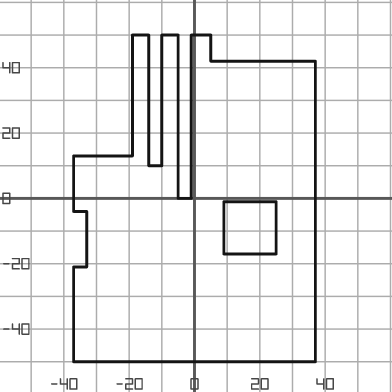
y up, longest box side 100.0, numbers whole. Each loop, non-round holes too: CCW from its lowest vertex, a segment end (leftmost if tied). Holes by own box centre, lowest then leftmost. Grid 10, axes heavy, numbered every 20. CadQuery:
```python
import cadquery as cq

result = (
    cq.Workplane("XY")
    .moveTo(-37.0, -50.0)
    .lineTo(37.0, -50.0)
    .lineTo(37.0, 42.0)
    .lineTo(5.0, 42.0)
    .lineTo(5.0, 50.0)
    .lineTo(-1.0, 50.0)
    .lineTo(-1.0, 0.0)
    .lineTo(-5.0, 0.0)
    .lineTo(-5.0, 50.0)
    .lineTo(-10.0, 50.0)
    .lineTo(-10.0, 10.0)
    .lineTo(-14.0, 10.0)
    .lineTo(-14.0, 50.0)
    .lineTo(-19.0, 50.0)
    .lineTo(-19.0, 13.0)
    .lineTo(-37.0, 13.0)
    .lineTo(-37.0, -4.0)
    .lineTo(-33.0, -4.0)
    .lineTo(-33.0, -21.0)
    .lineTo(-37.0, -21.0)
    .close()
    .moveTo(9.0, -17.0)
    .lineTo(25.0, -17.0)
    .lineTo(25.0, -1.0)
    .lineTo(9.0, -1.0)
    .close()
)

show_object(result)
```